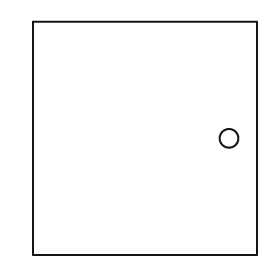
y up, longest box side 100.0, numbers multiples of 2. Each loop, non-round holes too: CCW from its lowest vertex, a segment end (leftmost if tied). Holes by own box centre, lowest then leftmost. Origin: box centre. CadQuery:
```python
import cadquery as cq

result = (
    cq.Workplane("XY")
    .moveTo(-48.0, -50.0)
    .lineTo(48.0, -50.0)
    .lineTo(48.0, 50.0)
    .lineTo(-48.0, 50.0)
    .close()
    .moveTo(36.0, 0.0)
    .circle(4.0)
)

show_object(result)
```